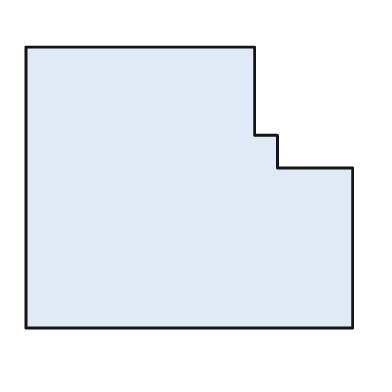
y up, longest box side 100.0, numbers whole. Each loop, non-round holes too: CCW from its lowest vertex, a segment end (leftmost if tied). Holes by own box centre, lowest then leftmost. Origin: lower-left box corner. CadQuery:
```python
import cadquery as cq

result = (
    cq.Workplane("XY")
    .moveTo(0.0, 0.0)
    .lineTo(100.0, 0.0)
    .lineTo(100.0, 49.0)
    .lineTo(77.0, 49.0)
    .lineTo(77.0, 59.0)
    .lineTo(70.0, 59.0)
    .lineTo(70.0, 86.0)
    .lineTo(0.0, 86.0)
    .close()
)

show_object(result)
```